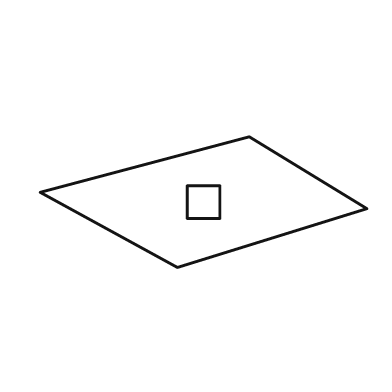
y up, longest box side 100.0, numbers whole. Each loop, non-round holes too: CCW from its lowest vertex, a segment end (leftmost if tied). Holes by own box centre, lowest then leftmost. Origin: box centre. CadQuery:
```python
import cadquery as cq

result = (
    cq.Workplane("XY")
    .moveTo(-8.0, -20.0)
    .lineTo(50.0, -2.0)
    .lineTo(14.0, 20.0)
    .lineTo(-50.0, 3.0)
    .close()
    .moveTo(-5.0, -5.0)
    .lineTo(5.0, -5.0)
    .lineTo(5.0, 5.0)
    .lineTo(-5.0, 5.0)
    .close()
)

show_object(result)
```